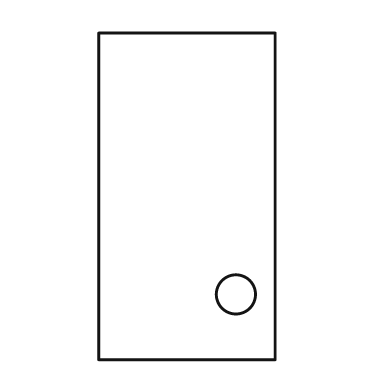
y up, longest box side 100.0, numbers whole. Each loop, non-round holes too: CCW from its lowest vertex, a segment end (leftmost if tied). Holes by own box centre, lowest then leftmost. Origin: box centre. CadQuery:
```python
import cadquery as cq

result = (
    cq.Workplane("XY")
    .moveTo(-27.0, -50.0)
    .lineTo(27.0, -50.0)
    .lineTo(27.0, 50.0)
    .lineTo(-27.0, 50.0)
    .close()
    .moveTo(15.0, -30.0)
    .circle(6.0)
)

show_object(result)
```